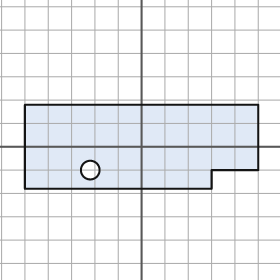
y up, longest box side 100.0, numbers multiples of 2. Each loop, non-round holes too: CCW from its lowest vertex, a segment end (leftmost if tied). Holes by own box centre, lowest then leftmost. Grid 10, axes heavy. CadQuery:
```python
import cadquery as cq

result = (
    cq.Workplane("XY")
    .moveTo(-50.0, -18.0)
    .lineTo(30.0, -18.0)
    .lineTo(30.0, -10.0)
    .lineTo(50.0, -10.0)
    .lineTo(50.0, 18.0)
    .lineTo(-50.0, 18.0)
    .close()
    .moveTo(-22.0, -10.0)
    .circle(4.0)
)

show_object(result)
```